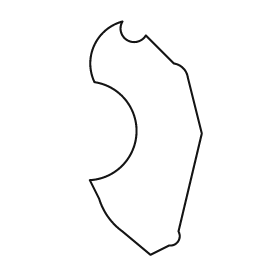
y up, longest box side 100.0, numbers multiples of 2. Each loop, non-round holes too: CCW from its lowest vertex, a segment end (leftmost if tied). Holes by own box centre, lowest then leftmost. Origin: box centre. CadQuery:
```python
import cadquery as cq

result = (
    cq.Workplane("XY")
    .moveTo(2.0, -50.0)
    .lineTo(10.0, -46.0)
    .threePointArc((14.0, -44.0), (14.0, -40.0))
    .lineTo(24.0, 2.0)
    .lineTo(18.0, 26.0)
    .threePointArc((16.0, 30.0), (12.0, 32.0))
    .lineTo(0.0, 44.0)
    .threePointArc((-8.0, 42.0), (-10.0, 50.0))
    .threePointArc((-22.0, 40.0), (-22.0, 24.0))
    .threePointArc((-4.0, 2.0), (-24.0, -18.0))
    .lineTo(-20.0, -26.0)
    .threePointArc((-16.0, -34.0), (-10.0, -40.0))
    .close()
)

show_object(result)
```